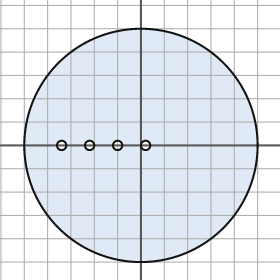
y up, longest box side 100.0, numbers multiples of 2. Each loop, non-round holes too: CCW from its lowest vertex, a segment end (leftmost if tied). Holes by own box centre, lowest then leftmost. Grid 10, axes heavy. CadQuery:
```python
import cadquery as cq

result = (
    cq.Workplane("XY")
    .moveTo(0.0, 0.0)
    .circle(50.0)
    .moveTo(-34.0, 0.0)
    .circle(2.0)
    .moveTo(-22.0, 0.0)
    .circle(2.0)
    .moveTo(-10.0, 0.0)
    .circle(2.0)
    .moveTo(2.0, 0.0)
    .circle(2.0)
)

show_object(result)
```